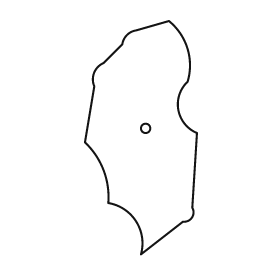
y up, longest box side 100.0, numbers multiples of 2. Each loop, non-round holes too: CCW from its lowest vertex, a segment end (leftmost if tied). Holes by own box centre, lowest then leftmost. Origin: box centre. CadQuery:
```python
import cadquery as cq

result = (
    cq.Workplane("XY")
    .moveTo(0.0, -50.0)
    .lineTo(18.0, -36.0)
    .threePointArc((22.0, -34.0), (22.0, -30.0))
    .lineTo(24.0, 2.0)
    .threePointArc((16.0, 12.0), (20.0, 24.0))
    .threePointArc((20.0, 38.0), (12.0, 50.0))
    .lineTo(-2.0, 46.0)
    .threePointArc((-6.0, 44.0), (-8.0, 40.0))
    .lineTo(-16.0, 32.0)
    .threePointArc((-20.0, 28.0), (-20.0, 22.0))
    .lineTo(-24.0, -2.0)
    .threePointArc((-16.0, -14.0), (-14.0, -28.0))
    .threePointArc((-2.0, -36.0), (0.0, -50.0))
    .close()
    .moveTo(2.0, 4.0)
    .circle(2.0)
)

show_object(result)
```